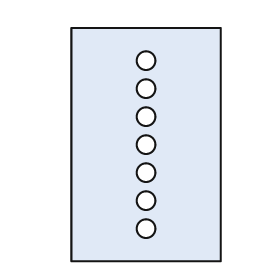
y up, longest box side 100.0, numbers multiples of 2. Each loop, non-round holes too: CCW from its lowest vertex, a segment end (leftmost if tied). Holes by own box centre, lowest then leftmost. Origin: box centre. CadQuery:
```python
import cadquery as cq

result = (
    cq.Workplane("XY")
    .moveTo(-32.0, -50.0)
    .lineTo(32.0, -50.0)
    .lineTo(32.0, 50.0)
    .lineTo(-32.0, 50.0)
    .close()
    .moveTo(0.0, -36.0)
    .circle(4.0)
    .moveTo(0.0, -24.0)
    .circle(4.0)
    .moveTo(0.0, -12.0)
    .circle(4.0)
    .moveTo(0.0, 0.0)
    .circle(4.0)
    .moveTo(0.0, 12.0)
    .circle(4.0)
    .moveTo(0.0, 24.0)
    .circle(4.0)
    .moveTo(0.0, 36.0)
    .circle(4.0)
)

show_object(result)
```